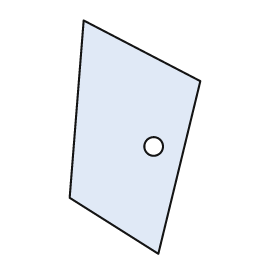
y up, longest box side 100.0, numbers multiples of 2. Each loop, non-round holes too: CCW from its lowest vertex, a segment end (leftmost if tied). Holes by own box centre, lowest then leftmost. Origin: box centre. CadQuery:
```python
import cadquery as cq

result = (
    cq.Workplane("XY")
    .moveTo(10.0, -50.0)
    .lineTo(28.0, 24.0)
    .lineTo(-22.0, 50.0)
    .lineTo(-28.0, -26.0)
    .close()
    .moveTo(8.0, -4.0)
    .circle(4.0)
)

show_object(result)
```